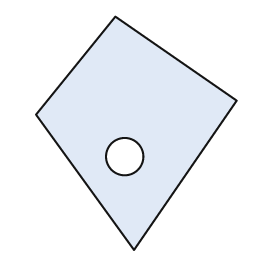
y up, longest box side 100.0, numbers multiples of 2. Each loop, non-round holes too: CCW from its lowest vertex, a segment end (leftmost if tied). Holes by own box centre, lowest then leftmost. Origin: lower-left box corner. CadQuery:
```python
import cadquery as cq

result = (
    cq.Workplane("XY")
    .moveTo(42.0, 0.0)
    .lineTo(86.0, 64.0)
    .lineTo(34.0, 100.0)
    .lineTo(0.0, 58.0)
    .close()
    .moveTo(38.0, 40.0)
    .circle(8.0)
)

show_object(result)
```